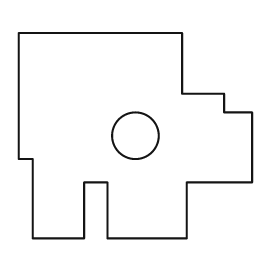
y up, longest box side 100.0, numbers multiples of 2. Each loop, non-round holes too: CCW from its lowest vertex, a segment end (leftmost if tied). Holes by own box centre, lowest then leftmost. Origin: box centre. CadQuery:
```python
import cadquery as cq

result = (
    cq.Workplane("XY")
    .moveTo(-44.0, -44.0)
    .lineTo(-22.0, -44.0)
    .lineTo(-22.0, -20.0)
    .lineTo(-12.0, -20.0)
    .lineTo(-12.0, -44.0)
    .lineTo(22.0, -44.0)
    .lineTo(22.0, -20.0)
    .lineTo(50.0, -20.0)
    .lineTo(50.0, 10.0)
    .lineTo(38.0, 10.0)
    .lineTo(38.0, 18.0)
    .lineTo(20.0, 18.0)
    .lineTo(20.0, 44.0)
    .lineTo(-50.0, 44.0)
    .lineTo(-50.0, -10.0)
    .lineTo(-44.0, -10.0)
    .close()
    .moveTo(0.0, 0.0)
    .circle(10.0)
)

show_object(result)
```